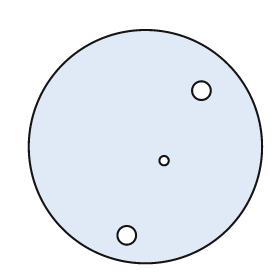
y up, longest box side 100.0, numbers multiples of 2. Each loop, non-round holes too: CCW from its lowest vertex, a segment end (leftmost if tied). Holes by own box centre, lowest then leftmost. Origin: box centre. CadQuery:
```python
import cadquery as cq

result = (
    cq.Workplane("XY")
    .moveTo(0.0, 0.0)
    .circle(50.0)
    .moveTo(-8.0, -38.0)
    .circle(4.0)
    .moveTo(8.0, -6.0)
    .circle(2.0)
    .moveTo(24.0, 24.0)
    .circle(4.0)
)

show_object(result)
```